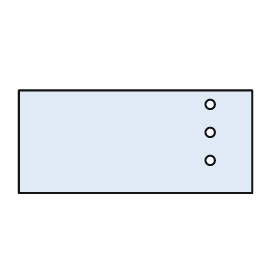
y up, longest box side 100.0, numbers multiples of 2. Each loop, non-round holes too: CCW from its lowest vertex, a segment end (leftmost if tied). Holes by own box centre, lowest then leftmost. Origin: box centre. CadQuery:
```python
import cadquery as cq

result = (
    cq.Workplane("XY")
    .moveTo(-50.0, -22.0)
    .lineTo(50.0, -22.0)
    .lineTo(50.0, 22.0)
    .lineTo(-50.0, 22.0)
    .close()
    .moveTo(32.0, -8.0)
    .circle(2.0)
    .moveTo(32.0, 4.0)
    .circle(2.0)
    .moveTo(32.0, 16.0)
    .circle(2.0)
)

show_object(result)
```